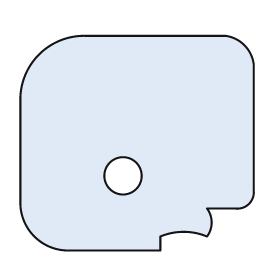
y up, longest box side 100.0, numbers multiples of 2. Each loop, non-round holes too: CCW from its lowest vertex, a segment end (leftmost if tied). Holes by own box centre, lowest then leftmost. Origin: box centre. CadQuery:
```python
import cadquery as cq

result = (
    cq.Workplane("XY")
    .moveTo(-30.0, -46.0)
    .lineTo(10.0, -46.0)
    .lineTo(10.0, -40.0)
    .threePointArc((20.0, -38.0), (30.0, -40.0))
    .threePointArc((32.0, -34.0), (30.0, -28.0))
    .lineTo(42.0, -28.0)
    .threePointArc((48.0, -26.0), (50.0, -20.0))
    .lineTo(50.0, 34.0)
    .threePointArc((46.0, 42.0), (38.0, 46.0))
    .lineTo(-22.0, 46.0)
    .threePointArc((-42.0, 38.0), (-50.0, 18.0))
    .lineTo(-50.0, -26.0)
    .threePointArc((-44.0, -40.0), (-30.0, -46.0))
    .close()
    .moveTo(-6.0, -14.0)
    .circle(8.0)
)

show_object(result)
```